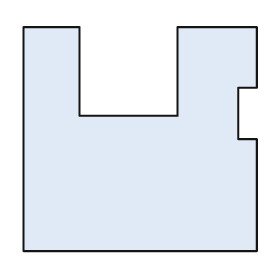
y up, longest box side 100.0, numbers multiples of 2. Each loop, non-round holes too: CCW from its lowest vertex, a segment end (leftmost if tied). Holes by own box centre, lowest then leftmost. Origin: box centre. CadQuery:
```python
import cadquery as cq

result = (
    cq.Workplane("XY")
    .moveTo(-50.0, -48.0)
    .lineTo(50.0, -48.0)
    .lineTo(50.0, 0.0)
    .lineTo(42.0, 0.0)
    .lineTo(42.0, 22.0)
    .lineTo(50.0, 22.0)
    .lineTo(50.0, 48.0)
    .lineTo(16.0, 48.0)
    .lineTo(16.0, 10.0)
    .lineTo(-26.0, 10.0)
    .lineTo(-26.0, 48.0)
    .lineTo(-50.0, 48.0)
    .close()
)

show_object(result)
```